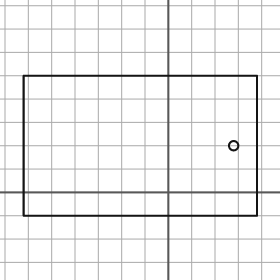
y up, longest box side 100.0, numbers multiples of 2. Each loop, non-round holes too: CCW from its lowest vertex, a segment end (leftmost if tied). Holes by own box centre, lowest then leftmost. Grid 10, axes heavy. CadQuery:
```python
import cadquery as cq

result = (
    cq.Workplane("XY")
    .moveTo(-62.0, -10.0)
    .lineTo(38.0, -10.0)
    .lineTo(38.0, 50.0)
    .lineTo(-62.0, 50.0)
    .close()
    .moveTo(28.0, 20.0)
    .circle(2.0)
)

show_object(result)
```